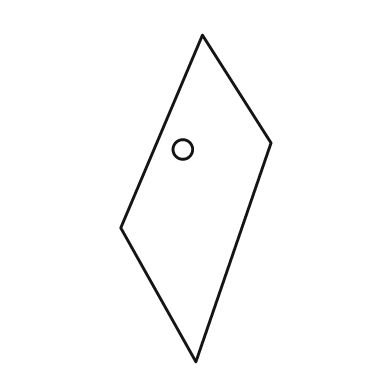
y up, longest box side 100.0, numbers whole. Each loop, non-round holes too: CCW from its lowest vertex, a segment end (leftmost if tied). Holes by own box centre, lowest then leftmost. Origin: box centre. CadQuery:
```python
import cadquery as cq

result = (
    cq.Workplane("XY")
    .moveTo(0.0, -50.0)
    .lineTo(23.0, 17.0)
    .lineTo(2.0, 50.0)
    .lineTo(-23.0, -9.0)
    .close()
    .moveTo(-4.0, 15.0)
    .circle(3.0)
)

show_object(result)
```